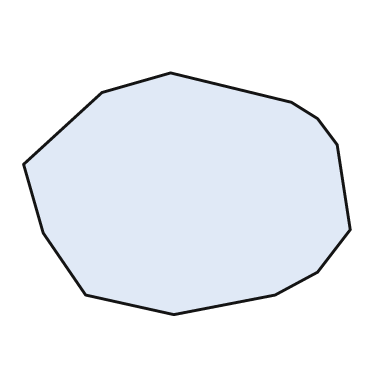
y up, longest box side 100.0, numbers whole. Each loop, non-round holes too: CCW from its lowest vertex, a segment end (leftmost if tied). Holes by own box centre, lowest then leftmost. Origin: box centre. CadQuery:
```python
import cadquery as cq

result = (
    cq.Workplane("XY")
    .moveTo(-4.0, -37.0)
    .lineTo(27.0, -31.0)
    .lineTo(40.0, -24.0)
    .lineTo(50.0, -11.0)
    .lineTo(46.0, 15.0)
    .lineTo(40.0, 23.0)
    .lineTo(32.0, 28.0)
    .lineTo(-5.0, 37.0)
    .lineTo(-26.0, 31.0)
    .lineTo(-50.0, 9.0)
    .lineTo(-44.0, -12.0)
    .lineTo(-31.0, -31.0)
    .close()
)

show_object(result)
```